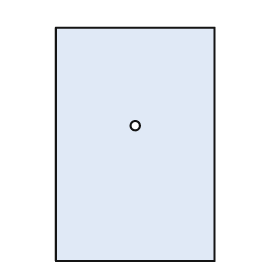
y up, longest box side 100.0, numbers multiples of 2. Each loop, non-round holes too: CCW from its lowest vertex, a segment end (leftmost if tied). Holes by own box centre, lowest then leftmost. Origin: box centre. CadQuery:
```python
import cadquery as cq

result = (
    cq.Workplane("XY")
    .moveTo(-34.0, -50.0)
    .lineTo(34.0, -50.0)
    .lineTo(34.0, 50.0)
    .lineTo(-34.0, 50.0)
    .close()
    .moveTo(0.0, 8.0)
    .circle(2.0)
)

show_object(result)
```